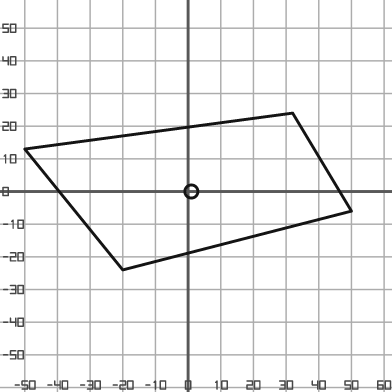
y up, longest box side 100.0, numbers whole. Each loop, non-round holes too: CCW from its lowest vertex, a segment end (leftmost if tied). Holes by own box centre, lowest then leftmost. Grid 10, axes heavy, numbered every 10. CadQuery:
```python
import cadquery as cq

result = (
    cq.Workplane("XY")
    .moveTo(-20.0, -24.0)
    .lineTo(50.0, -6.0)
    .lineTo(32.0, 24.0)
    .lineTo(-50.0, 13.0)
    .close()
    .moveTo(1.0, 0.0)
    .circle(2.0)
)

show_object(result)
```